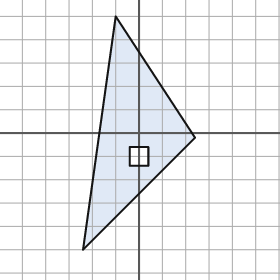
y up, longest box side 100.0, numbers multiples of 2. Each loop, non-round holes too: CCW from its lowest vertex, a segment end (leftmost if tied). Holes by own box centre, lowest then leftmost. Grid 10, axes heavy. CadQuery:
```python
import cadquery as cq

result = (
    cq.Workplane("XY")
    .moveTo(-24.0, -50.0)
    .lineTo(24.0, -2.0)
    .lineTo(-10.0, 50.0)
    .close()
    .moveTo(-4.0, -14.0)
    .lineTo(4.0, -14.0)
    .lineTo(4.0, -6.0)
    .lineTo(-4.0, -6.0)
    .close()
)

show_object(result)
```